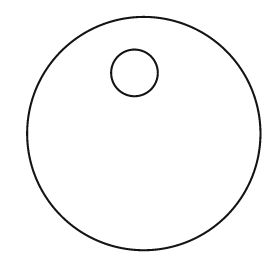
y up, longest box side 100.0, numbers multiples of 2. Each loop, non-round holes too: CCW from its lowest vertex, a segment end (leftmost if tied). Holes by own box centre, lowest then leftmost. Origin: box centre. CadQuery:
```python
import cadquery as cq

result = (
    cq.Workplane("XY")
    .moveTo(0.0, 0.0)
    .circle(50.0)
    .moveTo(-4.0, 26.0)
    .circle(10.0)
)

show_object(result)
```